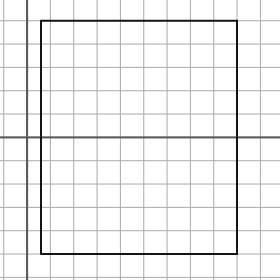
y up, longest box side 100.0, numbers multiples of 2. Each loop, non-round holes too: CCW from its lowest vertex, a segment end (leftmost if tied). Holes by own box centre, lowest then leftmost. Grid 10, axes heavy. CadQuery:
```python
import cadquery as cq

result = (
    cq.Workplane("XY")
    .moveTo(6.0, -50.0)
    .lineTo(90.0, -50.0)
    .lineTo(90.0, 50.0)
    .lineTo(6.0, 50.0)
    .close()
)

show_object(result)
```